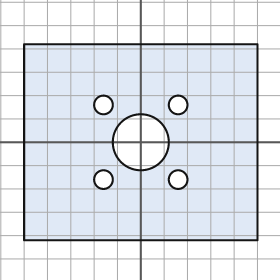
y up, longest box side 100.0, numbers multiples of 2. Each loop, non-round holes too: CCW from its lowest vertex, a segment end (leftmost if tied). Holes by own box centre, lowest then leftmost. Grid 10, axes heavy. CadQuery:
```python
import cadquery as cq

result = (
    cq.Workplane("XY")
    .moveTo(-50.0, -42.0)
    .lineTo(50.0, -42.0)
    .lineTo(50.0, 42.0)
    .lineTo(-50.0, 42.0)
    .close()
    .moveTo(-16.0, -16.0)
    .circle(4.0)
    .moveTo(16.0, -16.0)
    .circle(4.0)
    .moveTo(0.0, 0.0)
    .circle(12.0)
    .moveTo(-16.0, 16.0)
    .circle(4.0)
    .moveTo(16.0, 16.0)
    .circle(4.0)
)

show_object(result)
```